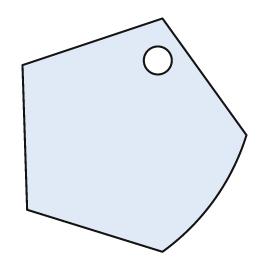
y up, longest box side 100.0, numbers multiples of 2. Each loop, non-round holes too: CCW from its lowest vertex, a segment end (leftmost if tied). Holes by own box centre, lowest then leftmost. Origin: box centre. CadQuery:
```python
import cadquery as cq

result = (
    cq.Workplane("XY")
    .moveTo(12.0, -50.0)
    .threePointArc((34.0, -28.0), (48.0, 0.0))
    .lineTo(12.0, 50.0)
    .lineTo(-48.0, 30.0)
    .lineTo(-46.0, -32.0)
    .close()
    .moveTo(10.0, 32.0)
    .circle(6.0)
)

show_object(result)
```